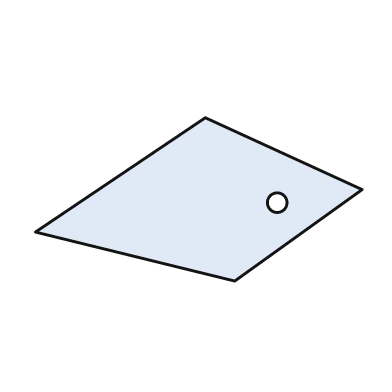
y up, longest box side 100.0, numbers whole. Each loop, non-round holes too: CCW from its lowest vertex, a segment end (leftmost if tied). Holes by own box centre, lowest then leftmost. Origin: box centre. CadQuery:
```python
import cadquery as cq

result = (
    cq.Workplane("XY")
    .moveTo(11.0, -25.0)
    .lineTo(50.0, 3.0)
    .lineTo(2.0, 25.0)
    .lineTo(-50.0, -10.0)
    .close()
    .moveTo(24.0, -1.0)
    .circle(3.0)
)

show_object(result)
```